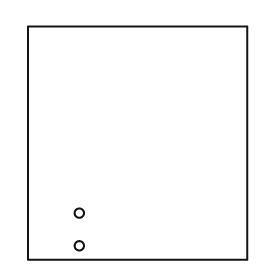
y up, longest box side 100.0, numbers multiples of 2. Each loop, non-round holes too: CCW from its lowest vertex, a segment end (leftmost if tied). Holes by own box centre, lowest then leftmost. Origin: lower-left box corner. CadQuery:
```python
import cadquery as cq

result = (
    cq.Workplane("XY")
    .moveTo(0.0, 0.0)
    .lineTo(94.0, 0.0)
    .lineTo(94.0, 100.0)
    .lineTo(0.0, 100.0)
    .close()
    .moveTo(22.0, 6.0)
    .circle(2.0)
    .moveTo(22.0, 20.0)
    .circle(2.0)
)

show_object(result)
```